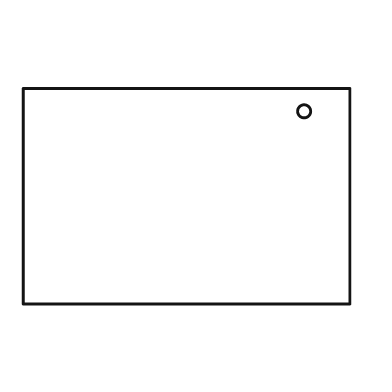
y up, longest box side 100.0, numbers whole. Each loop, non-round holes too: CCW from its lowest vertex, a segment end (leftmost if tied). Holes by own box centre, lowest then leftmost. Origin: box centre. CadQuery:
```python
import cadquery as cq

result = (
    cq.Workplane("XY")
    .moveTo(-50.0, -33.0)
    .lineTo(50.0, -33.0)
    .lineTo(50.0, 33.0)
    .lineTo(-50.0, 33.0)
    .close()
    .moveTo(36.0, 26.0)
    .circle(2.0)
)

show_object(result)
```